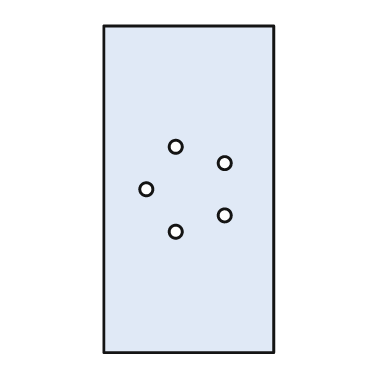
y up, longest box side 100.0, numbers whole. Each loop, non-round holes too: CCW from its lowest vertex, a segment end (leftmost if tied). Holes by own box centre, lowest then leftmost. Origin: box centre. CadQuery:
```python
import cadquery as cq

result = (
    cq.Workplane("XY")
    .moveTo(-26.0, -50.0)
    .lineTo(26.0, -50.0)
    .lineTo(26.0, 50.0)
    .lineTo(-26.0, 50.0)
    .close()
    .moveTo(-4.0, -13.0)
    .circle(2.0)
    .moveTo(11.0, -8.0)
    .circle(2.0)
    .moveTo(-13.0, 0.0)
    .circle(2.0)
    .moveTo(11.0, 8.0)
    .circle(2.0)
    .moveTo(-4.0, 13.0)
    .circle(2.0)
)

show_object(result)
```